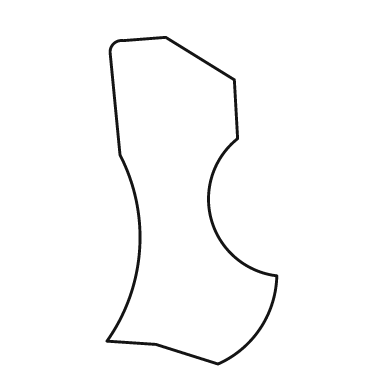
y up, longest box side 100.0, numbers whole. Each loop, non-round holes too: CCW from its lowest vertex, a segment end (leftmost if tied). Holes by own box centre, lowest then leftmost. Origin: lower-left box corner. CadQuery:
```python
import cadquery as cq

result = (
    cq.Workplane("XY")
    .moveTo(34.0, 0.0)
    .threePointArc((47.0, 11.0), (52.0, 27.0))
    .threePointArc((32.0, 44.0), (40.0, 69.0))
    .lineTo(39.0, 87.0)
    .lineTo(18.0, 100.0)
    .lineTo(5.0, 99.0)
    .threePointArc((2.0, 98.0), (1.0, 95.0))
    .lineTo(4.0, 64.0)
    .threePointArc((10.0, 35.0), (0.0, 7.0))
    .lineTo(15.0, 6.0)
    .close()
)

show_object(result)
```